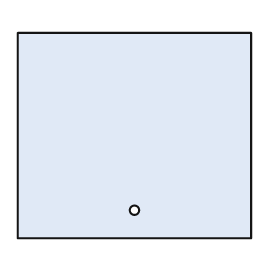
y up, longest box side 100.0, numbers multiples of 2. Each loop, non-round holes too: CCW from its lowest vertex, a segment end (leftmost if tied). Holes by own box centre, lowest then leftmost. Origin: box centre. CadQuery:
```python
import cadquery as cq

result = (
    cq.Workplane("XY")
    .moveTo(-50.0, -44.0)
    .lineTo(50.0, -44.0)
    .lineTo(50.0, 44.0)
    .lineTo(-50.0, 44.0)
    .close()
    .moveTo(0.0, -32.0)
    .circle(2.0)
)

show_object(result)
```